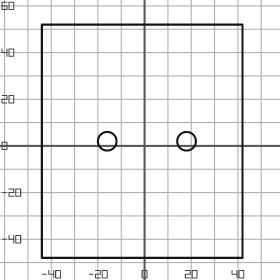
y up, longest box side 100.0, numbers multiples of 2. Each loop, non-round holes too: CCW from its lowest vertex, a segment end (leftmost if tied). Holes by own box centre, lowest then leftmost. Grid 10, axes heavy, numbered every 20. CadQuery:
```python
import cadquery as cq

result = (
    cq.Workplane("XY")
    .moveTo(-44.0, -48.0)
    .lineTo(42.0, -48.0)
    .lineTo(42.0, 52.0)
    .lineTo(-44.0, 52.0)
    .close()
    .moveTo(-16.0, 2.0)
    .circle(4.0)
    .moveTo(18.0, 2.0)
    .circle(4.0)
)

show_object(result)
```